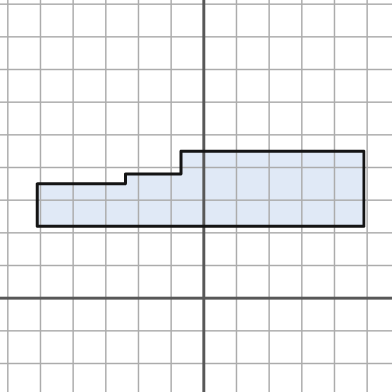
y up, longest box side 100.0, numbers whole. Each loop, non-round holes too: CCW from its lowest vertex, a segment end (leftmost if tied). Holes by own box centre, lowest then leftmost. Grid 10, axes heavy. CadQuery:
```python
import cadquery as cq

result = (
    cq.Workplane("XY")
    .moveTo(-51.0, 22.0)
    .lineTo(49.0, 22.0)
    .lineTo(49.0, 45.0)
    .lineTo(-7.0, 45.0)
    .lineTo(-7.0, 38.0)
    .lineTo(-24.0, 38.0)
    .lineTo(-24.0, 35.0)
    .lineTo(-51.0, 35.0)
    .close()
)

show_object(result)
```